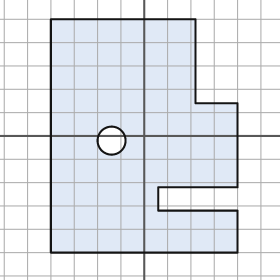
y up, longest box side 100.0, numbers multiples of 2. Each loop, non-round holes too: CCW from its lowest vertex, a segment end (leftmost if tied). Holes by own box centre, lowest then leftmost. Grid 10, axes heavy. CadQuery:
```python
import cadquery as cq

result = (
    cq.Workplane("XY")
    .moveTo(-40.0, -50.0)
    .lineTo(40.0, -50.0)
    .lineTo(40.0, -32.0)
    .lineTo(6.0, -32.0)
    .lineTo(6.0, -22.0)
    .lineTo(40.0, -22.0)
    .lineTo(40.0, 14.0)
    .lineTo(22.0, 14.0)
    .lineTo(22.0, 50.0)
    .lineTo(-40.0, 50.0)
    .close()
    .moveTo(-14.0, -2.0)
    .circle(6.0)
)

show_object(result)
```